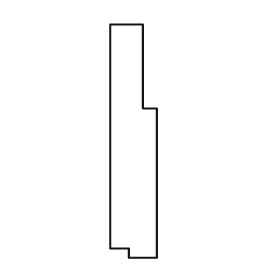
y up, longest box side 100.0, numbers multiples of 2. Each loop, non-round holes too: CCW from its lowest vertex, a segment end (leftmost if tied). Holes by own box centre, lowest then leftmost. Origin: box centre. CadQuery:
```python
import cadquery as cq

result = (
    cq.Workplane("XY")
    .moveTo(-2.0, -50.0)
    .lineTo(10.0, -50.0)
    .lineTo(10.0, 14.0)
    .lineTo(4.0, 14.0)
    .lineTo(4.0, 50.0)
    .lineTo(-10.0, 50.0)
    .lineTo(-10.0, -46.0)
    .lineTo(-2.0, -46.0)
    .close()
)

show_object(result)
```